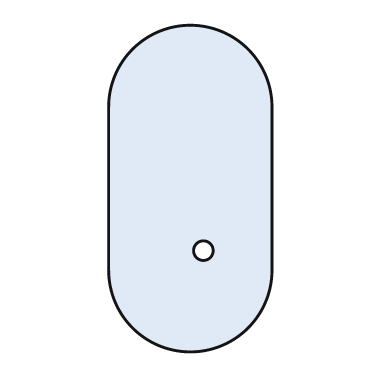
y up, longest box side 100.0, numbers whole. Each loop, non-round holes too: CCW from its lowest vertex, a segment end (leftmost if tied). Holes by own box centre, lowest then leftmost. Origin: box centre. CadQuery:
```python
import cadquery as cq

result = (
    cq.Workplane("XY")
    .moveTo(-25.0, -25.0)
    .threePointArc((0.0, -50.0), (25.0, -25.0))
    .lineTo(25.0, 25.0)
    .threePointArc((0.0, 50.0), (-25.0, 25.0))
    .close()
    .moveTo(4.0, -19.0)
    .circle(3.0)
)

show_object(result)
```